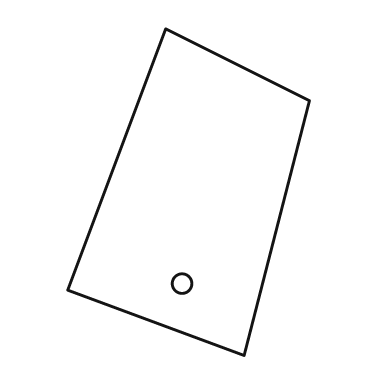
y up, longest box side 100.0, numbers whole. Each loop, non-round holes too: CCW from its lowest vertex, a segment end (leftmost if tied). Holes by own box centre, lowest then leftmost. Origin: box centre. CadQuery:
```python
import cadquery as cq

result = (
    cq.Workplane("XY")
    .moveTo(17.0, -50.0)
    .lineTo(37.0, 28.0)
    .lineTo(-7.0, 50.0)
    .lineTo(-37.0, -30.0)
    .close()
    .moveTo(-2.0, -28.0)
    .circle(3.0)
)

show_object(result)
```